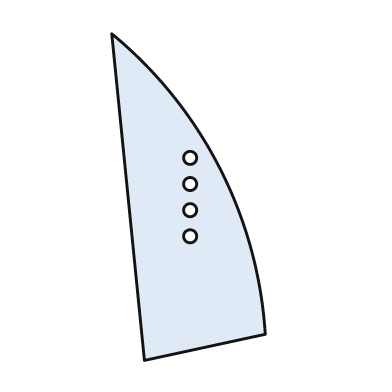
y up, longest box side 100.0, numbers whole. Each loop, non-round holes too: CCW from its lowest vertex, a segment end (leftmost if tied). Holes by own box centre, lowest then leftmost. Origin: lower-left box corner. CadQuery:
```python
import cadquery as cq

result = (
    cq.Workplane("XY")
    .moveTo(10.0, 0.0)
    .lineTo(47.0, 8.0)
    .threePointArc((33.0, 59.0), (0.0, 100.0))
    .close()
    .moveTo(24.0, 38.0)
    .circle(2.0)
    .moveTo(24.0, 46.0)
    .circle(2.0)
    .moveTo(24.0, 54.0)
    .circle(2.0)
    .moveTo(24.0, 62.0)
    .circle(2.0)
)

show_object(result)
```